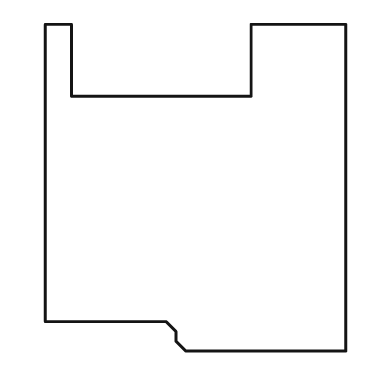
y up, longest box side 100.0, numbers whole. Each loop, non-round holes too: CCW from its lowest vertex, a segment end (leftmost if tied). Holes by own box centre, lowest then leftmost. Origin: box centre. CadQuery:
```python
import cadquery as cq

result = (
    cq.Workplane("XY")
    .moveTo(-3.0, -50.0)
    .lineTo(46.0, -50.0)
    .lineTo(46.0, 50.0)
    .lineTo(17.0, 50.0)
    .lineTo(17.0, 28.0)
    .lineTo(-38.0, 28.0)
    .lineTo(-38.0, 50.0)
    .lineTo(-46.0, 50.0)
    .lineTo(-46.0, -41.0)
    .lineTo(-9.0, -41.0)
    .lineTo(-6.0, -44.0)
    .lineTo(-6.0, -47.0)
    .close()
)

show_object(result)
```